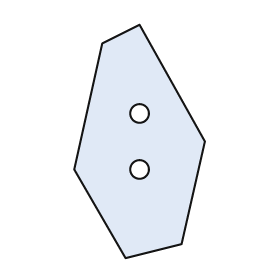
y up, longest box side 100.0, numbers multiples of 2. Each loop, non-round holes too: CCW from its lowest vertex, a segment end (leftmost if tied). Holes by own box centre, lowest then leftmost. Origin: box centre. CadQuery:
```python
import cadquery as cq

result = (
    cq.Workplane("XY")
    .moveTo(-6.0, -50.0)
    .lineTo(18.0, -44.0)
    .lineTo(28.0, 0.0)
    .lineTo(0.0, 50.0)
    .lineTo(-16.0, 42.0)
    .lineTo(-28.0, -12.0)
    .close()
    .moveTo(0.0, -12.0)
    .circle(4.0)
    .moveTo(0.0, 12.0)
    .circle(4.0)
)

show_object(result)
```